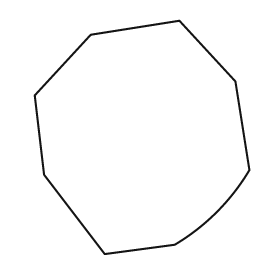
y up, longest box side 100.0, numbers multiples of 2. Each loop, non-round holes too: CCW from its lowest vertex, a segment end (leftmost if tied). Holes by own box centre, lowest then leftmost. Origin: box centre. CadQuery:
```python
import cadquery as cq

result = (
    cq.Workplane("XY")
    .moveTo(-16.0, -50.0)
    .lineTo(14.0, -46.0)
    .threePointArc((32.0, -32.0), (46.0, -14.0))
    .lineTo(40.0, 24.0)
    .lineTo(16.0, 50.0)
    .lineTo(-22.0, 44.0)
    .lineTo(-46.0, 18.0)
    .lineTo(-42.0, -16.0)
    .close()
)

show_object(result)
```